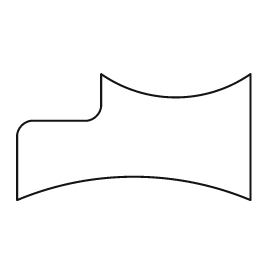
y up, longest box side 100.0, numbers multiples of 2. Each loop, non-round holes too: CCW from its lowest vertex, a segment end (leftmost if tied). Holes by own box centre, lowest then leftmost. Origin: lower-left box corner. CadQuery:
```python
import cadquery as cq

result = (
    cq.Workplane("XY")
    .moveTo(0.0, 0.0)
    .threePointArc((50.0, 10.0), (100.0, 0.0))
    .lineTo(100.0, 54.0)
    .threePointArc((68.0, 44.0), (36.0, 54.0))
    .lineTo(36.0, 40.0)
    .threePointArc((34.0, 36.0), (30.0, 34.0))
    .lineTo(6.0, 34.0)
    .threePointArc((2.0, 32.0), (0.0, 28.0))
    .close()
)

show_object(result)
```